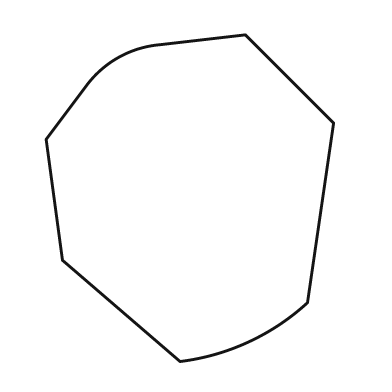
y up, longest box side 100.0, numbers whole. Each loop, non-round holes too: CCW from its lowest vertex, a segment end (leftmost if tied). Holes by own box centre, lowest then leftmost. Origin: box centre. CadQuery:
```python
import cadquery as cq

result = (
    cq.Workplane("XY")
    .moveTo(-3.0, -50.0)
    .threePointArc((18.0, -44.0), (36.0, -32.0))
    .lineTo(44.0, 23.0)
    .lineTo(17.0, 50.0)
    .lineTo(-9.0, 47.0)
    .threePointArc((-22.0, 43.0), (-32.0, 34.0))
    .lineTo(-44.0, 18.0)
    .lineTo(-39.0, -19.0)
    .close()
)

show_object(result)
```